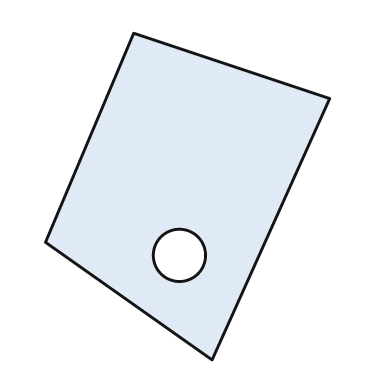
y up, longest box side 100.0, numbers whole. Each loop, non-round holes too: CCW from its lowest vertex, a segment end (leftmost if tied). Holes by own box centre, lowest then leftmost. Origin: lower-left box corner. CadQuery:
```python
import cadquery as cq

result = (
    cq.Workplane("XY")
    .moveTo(51.0, 0.0)
    .lineTo(87.0, 80.0)
    .lineTo(27.0, 100.0)
    .lineTo(0.0, 36.0)
    .close()
    .moveTo(41.0, 32.0)
    .circle(8.0)
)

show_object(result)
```